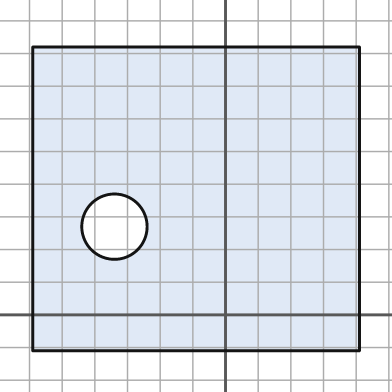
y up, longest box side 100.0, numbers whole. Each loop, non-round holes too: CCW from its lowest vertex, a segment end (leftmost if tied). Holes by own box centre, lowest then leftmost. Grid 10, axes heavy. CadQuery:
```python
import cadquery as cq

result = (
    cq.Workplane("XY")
    .moveTo(-59.0, -11.0)
    .lineTo(41.0, -11.0)
    .lineTo(41.0, 82.0)
    .lineTo(-59.0, 82.0)
    .close()
    .moveTo(-34.0, 27.0)
    .circle(10.0)
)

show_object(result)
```